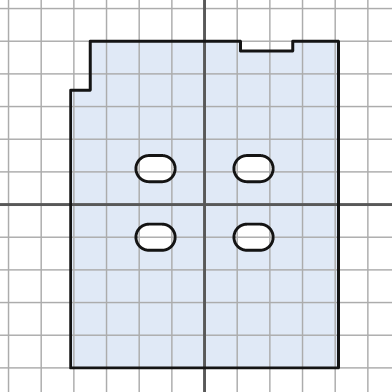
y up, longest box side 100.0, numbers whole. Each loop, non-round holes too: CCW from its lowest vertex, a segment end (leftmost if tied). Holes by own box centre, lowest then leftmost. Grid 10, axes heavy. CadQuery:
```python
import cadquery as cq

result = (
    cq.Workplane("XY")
    .moveTo(-41.0, -50.0)
    .lineTo(41.0, -50.0)
    .lineTo(41.0, 50.0)
    .lineTo(27.0, 50.0)
    .lineTo(27.0, 47.0)
    .lineTo(11.0, 47.0)
    .lineTo(11.0, 50.0)
    .lineTo(-35.0, 50.0)
    .lineTo(-35.0, 35.0)
    .lineTo(-41.0, 35.0)
    .close()
    .moveTo(-17.0, -14.0)
    .lineTo(-13.0, -14.0)
    .threePointArc((-9.0, -10.0), (-13.0, -6.0))
    .lineTo(-17.0, -6.0)
    .threePointArc((-21.0, -10.0), (-17.0, -14.0))
    .close()
    .moveTo(13.0, -14.0)
    .lineTo(17.0, -14.0)
    .threePointArc((21.0, -10.0), (17.0, -6.0))
    .lineTo(13.0, -6.0)
    .threePointArc((9.0, -10.0), (13.0, -14.0))
    .close()
    .moveTo(-17.0, 7.0)
    .lineTo(-13.0, 7.0)
    .threePointArc((-9.0, 11.0), (-13.0, 15.0))
    .lineTo(-17.0, 15.0)
    .threePointArc((-21.0, 11.0), (-17.0, 7.0))
    .close()
    .moveTo(13.0, 7.0)
    .lineTo(17.0, 7.0)
    .threePointArc((21.0, 11.0), (17.0, 15.0))
    .lineTo(13.0, 15.0)
    .threePointArc((9.0, 11.0), (13.0, 7.0))
    .close()
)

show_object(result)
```